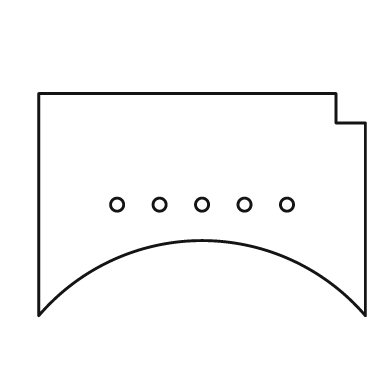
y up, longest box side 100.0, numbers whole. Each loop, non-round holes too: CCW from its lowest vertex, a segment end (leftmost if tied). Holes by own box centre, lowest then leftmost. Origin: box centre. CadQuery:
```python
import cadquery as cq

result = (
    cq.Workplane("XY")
    .moveTo(-50.0, -34.0)
    .threePointArc((0.0, -11.0), (50.0, -34.0))
    .lineTo(50.0, 25.0)
    .lineTo(41.0, 25.0)
    .lineTo(41.0, 34.0)
    .lineTo(-50.0, 34.0)
    .close()
    .moveTo(-26.0, 0.0)
    .circle(2.0)
    .moveTo(-13.0, 0.0)
    .circle(2.0)
    .moveTo(0.0, 0.0)
    .circle(2.0)
    .moveTo(13.0, 0.0)
    .circle(2.0)
    .moveTo(26.0, 0.0)
    .circle(2.0)
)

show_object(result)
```